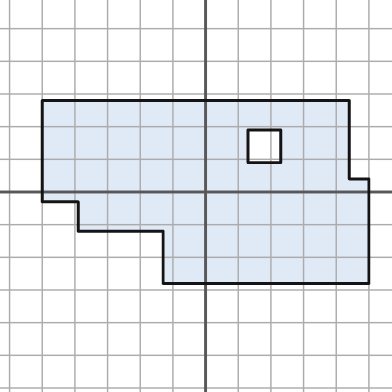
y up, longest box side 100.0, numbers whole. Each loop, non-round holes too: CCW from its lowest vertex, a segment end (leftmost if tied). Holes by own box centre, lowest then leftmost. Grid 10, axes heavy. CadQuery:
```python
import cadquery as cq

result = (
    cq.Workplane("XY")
    .moveTo(-13.0, -28.0)
    .lineTo(50.0, -28.0)
    .lineTo(50.0, 4.0)
    .lineTo(44.0, 4.0)
    .lineTo(44.0, 28.0)
    .lineTo(-50.0, 28.0)
    .lineTo(-50.0, -3.0)
    .lineTo(-39.0, -3.0)
    .lineTo(-39.0, -12.0)
    .lineTo(-13.0, -12.0)
    .close()
    .moveTo(13.0, 9.0)
    .lineTo(23.0, 9.0)
    .lineTo(23.0, 19.0)
    .lineTo(13.0, 19.0)
    .close()
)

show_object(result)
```